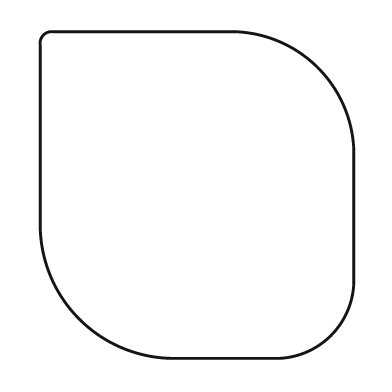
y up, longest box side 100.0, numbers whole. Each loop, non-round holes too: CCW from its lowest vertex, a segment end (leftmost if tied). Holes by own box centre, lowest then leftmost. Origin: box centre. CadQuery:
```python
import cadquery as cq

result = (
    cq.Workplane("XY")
    .moveTo(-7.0, -50.0)
    .lineTo(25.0, -50.0)
    .threePointArc((41.0, -43.0), (48.0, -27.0))
    .lineTo(48.0, 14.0)
    .threePointArc((37.0, 39.0), (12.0, 50.0))
    .lineTo(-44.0, 50.0)
    .threePointArc((-47.0, 49.0), (-48.0, 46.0))
    .lineTo(-48.0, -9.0)
    .threePointArc((-36.0, -38.0), (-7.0, -50.0))
    .close()
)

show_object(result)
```